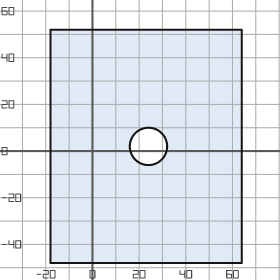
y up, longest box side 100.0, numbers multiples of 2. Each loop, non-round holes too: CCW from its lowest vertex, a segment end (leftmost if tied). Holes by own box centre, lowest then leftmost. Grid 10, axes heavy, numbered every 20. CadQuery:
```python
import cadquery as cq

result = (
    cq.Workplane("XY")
    .moveTo(-18.0, -48.0)
    .lineTo(64.0, -48.0)
    .lineTo(64.0, 52.0)
    .lineTo(-18.0, 52.0)
    .close()
    .moveTo(24.0, 2.0)
    .circle(8.0)
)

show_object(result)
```